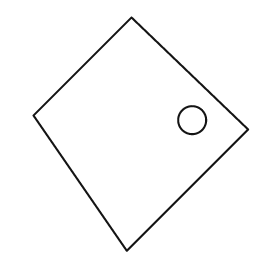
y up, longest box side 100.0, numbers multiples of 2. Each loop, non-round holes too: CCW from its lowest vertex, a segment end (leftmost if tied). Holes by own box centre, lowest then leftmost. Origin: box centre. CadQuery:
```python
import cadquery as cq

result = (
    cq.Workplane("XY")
    .moveTo(-6.0, -50.0)
    .lineTo(46.0, 2.0)
    .lineTo(-4.0, 50.0)
    .lineTo(-46.0, 8.0)
    .close()
    .moveTo(22.0, 6.0)
    .circle(6.0)
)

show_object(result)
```